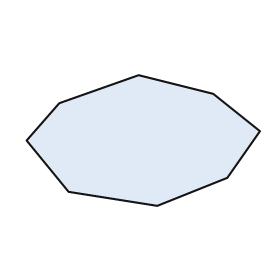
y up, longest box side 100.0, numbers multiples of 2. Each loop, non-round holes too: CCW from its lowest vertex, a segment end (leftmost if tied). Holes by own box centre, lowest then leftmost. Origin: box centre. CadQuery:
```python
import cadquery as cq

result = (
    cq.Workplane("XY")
    .moveTo(6.0, -28.0)
    .lineTo(36.0, -16.0)
    .lineTo(50.0, 4.0)
    .lineTo(30.0, 20.0)
    .lineTo(-2.0, 28.0)
    .lineTo(-36.0, 16.0)
    .lineTo(-50.0, 0.0)
    .lineTo(-32.0, -22.0)
    .close()
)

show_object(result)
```